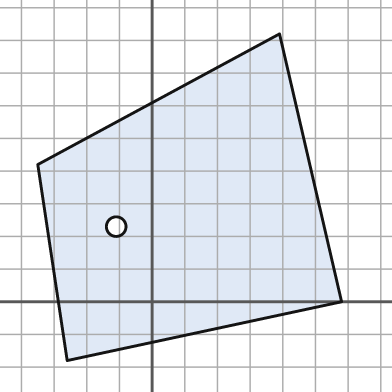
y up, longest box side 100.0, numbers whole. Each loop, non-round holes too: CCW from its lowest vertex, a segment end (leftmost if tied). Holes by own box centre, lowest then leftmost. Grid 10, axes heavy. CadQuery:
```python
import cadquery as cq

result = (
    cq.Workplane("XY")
    .moveTo(-26.0, -18.0)
    .lineTo(58.0, 0.0)
    .lineTo(39.0, 82.0)
    .lineTo(-35.0, 42.0)
    .close()
    .moveTo(-11.0, 23.0)
    .circle(3.0)
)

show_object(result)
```